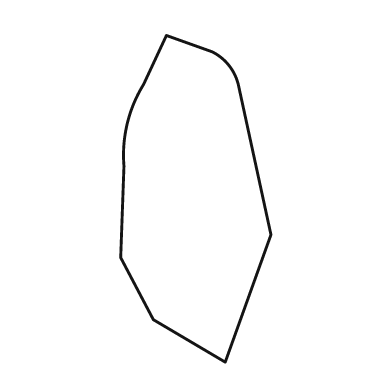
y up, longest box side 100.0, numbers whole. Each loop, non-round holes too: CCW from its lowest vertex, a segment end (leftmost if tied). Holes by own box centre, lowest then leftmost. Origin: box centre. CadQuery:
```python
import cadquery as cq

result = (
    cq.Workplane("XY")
    .moveTo(9.0, -50.0)
    .lineTo(23.0, -11.0)
    .lineTo(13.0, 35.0)
    .threePointArc((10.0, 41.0), (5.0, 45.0))
    .lineTo(-9.0, 50.0)
    .lineTo(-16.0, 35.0)
    .threePointArc((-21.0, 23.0), (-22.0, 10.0))
    .lineTo(-23.0, -18.0)
    .lineTo(-13.0, -37.0)
    .close()
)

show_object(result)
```